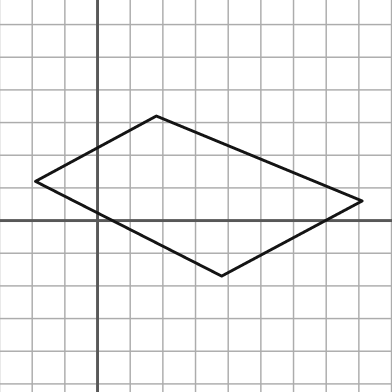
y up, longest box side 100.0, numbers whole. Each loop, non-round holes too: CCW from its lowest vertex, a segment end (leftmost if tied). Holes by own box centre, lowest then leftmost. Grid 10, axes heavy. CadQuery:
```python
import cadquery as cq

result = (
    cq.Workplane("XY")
    .moveTo(38.0, -17.0)
    .lineTo(81.0, 6.0)
    .lineTo(18.0, 32.0)
    .lineTo(-19.0, 12.0)
    .close()
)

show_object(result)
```